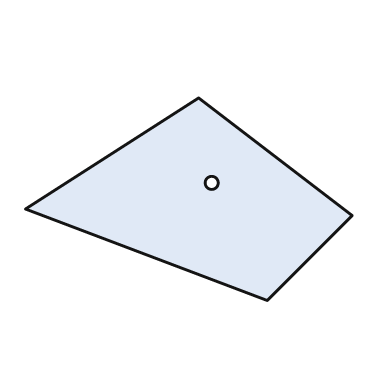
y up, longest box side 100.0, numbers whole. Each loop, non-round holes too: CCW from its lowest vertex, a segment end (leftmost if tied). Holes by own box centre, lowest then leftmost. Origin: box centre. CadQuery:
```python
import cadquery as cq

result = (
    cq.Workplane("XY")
    .moveTo(24.0, -31.0)
    .lineTo(50.0, -5.0)
    .lineTo(3.0, 31.0)
    .lineTo(-50.0, -3.0)
    .close()
    .moveTo(7.0, 5.0)
    .circle(2.0)
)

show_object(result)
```